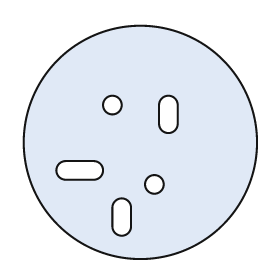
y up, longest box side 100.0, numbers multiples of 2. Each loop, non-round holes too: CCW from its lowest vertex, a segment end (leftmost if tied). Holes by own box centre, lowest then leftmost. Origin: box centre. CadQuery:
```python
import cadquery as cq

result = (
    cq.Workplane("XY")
    .moveTo(0.0, 0.0)
    .circle(50.0)
    .moveTo(-12.0, -36.0)
    .threePointArc((-8.0, -40.0), (-4.0, -36.0))
    .lineTo(-4.0, -28.0)
    .threePointArc((-8.0, -24.0), (-12.0, -28.0))
    .close()
    .moveTo(6.0, -18.0)
    .circle(4.0)
    .moveTo(-32.0, -16.0)
    .lineTo(-20.0, -16.0)
    .threePointArc((-16.0, -12.0), (-20.0, -8.0))
    .lineTo(-32.0, -8.0)
    .threePointArc((-36.0, -12.0), (-32.0, -16.0))
    .close()
    .moveTo(8.0, 8.0)
    .threePointArc((12.0, 4.0), (16.0, 8.0))
    .lineTo(16.0, 16.0)
    .threePointArc((12.0, 20.0), (8.0, 16.0))
    .close()
    .moveTo(-12.0, 16.0)
    .circle(4.0)
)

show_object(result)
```